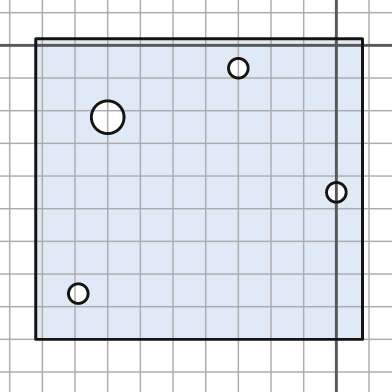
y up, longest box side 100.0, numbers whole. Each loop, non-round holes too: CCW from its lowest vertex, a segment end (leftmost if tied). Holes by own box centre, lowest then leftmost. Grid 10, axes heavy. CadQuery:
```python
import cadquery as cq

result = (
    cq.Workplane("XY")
    .moveTo(-92.0, -90.0)
    .lineTo(8.0, -90.0)
    .lineTo(8.0, 2.0)
    .lineTo(-92.0, 2.0)
    .close()
    .moveTo(-79.0, -76.0)
    .circle(3.0)
    .moveTo(0.0, -45.0)
    .circle(3.0)
    .moveTo(-70.0, -22.0)
    .circle(5.0)
    .moveTo(-30.0, -7.0)
    .circle(3.0)
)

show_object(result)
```